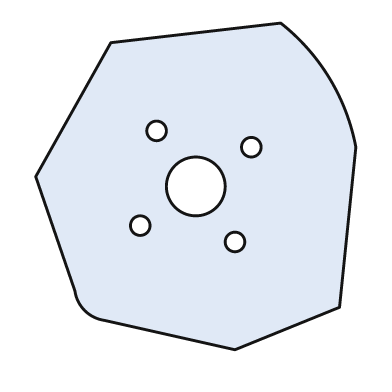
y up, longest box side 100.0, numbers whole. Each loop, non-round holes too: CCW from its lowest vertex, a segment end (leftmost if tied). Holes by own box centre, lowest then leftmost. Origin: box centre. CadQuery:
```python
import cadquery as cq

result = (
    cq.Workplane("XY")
    .moveTo(12.0, -50.0)
    .lineTo(44.0, -37.0)
    .lineTo(49.0, 12.0)
    .threePointArc((41.0, 33.0), (26.0, 50.0))
    .lineTo(-26.0, 44.0)
    .lineTo(-49.0, 3.0)
    .lineTo(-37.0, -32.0)
    .threePointArc((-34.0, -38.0), (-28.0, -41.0))
    .close()
    .moveTo(12.0, -17.0)
    .circle(3.0)
    .moveTo(-17.0, -12.0)
    .circle(3.0)
    .moveTo(0.0, 0.0)
    .circle(9.0)
    .moveTo(17.0, 12.0)
    .circle(3.0)
    .moveTo(-12.0, 17.0)
    .circle(3.0)
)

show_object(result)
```